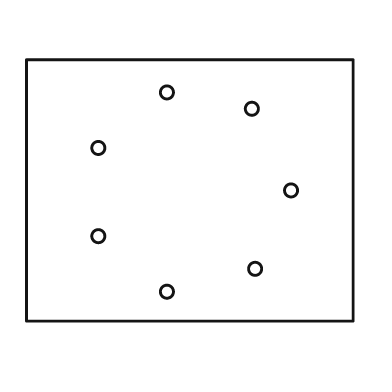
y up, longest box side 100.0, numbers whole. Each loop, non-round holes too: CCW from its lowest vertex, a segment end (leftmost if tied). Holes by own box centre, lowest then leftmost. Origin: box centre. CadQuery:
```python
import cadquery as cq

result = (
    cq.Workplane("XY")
    .moveTo(-50.0, -40.0)
    .lineTo(50.0, -40.0)
    .lineTo(50.0, 40.0)
    .lineTo(-50.0, 40.0)
    .close()
    .moveTo(-7.0, -31.0)
    .circle(2.0)
    .moveTo(20.0, -24.0)
    .circle(2.0)
    .moveTo(-28.0, -14.0)
    .circle(2.0)
    .moveTo(31.0, 0.0)
    .circle(2.0)
    .moveTo(-28.0, 13.0)
    .circle(2.0)
    .moveTo(19.0, 25.0)
    .circle(2.0)
    .moveTo(-7.0, 30.0)
    .circle(2.0)
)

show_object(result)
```